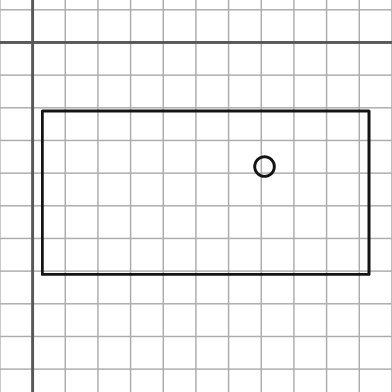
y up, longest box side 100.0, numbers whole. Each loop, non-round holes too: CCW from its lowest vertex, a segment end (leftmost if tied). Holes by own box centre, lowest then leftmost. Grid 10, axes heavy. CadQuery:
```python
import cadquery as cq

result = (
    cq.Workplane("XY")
    .moveTo(3.0, -71.0)
    .lineTo(103.0, -71.0)
    .lineTo(103.0, -21.0)
    .lineTo(3.0, -21.0)
    .close()
    .moveTo(71.0, -38.0)
    .circle(3.0)
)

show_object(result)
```